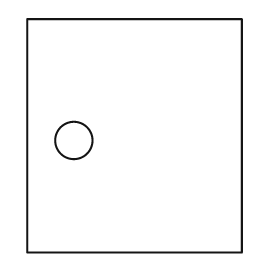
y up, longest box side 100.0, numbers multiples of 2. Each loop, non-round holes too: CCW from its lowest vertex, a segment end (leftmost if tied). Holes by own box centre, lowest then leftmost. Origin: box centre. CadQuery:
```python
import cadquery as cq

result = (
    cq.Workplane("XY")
    .moveTo(-46.0, -50.0)
    .lineTo(46.0, -50.0)
    .lineTo(46.0, 50.0)
    .lineTo(-46.0, 50.0)
    .close()
    .moveTo(-26.0, -2.0)
    .circle(8.0)
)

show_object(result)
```